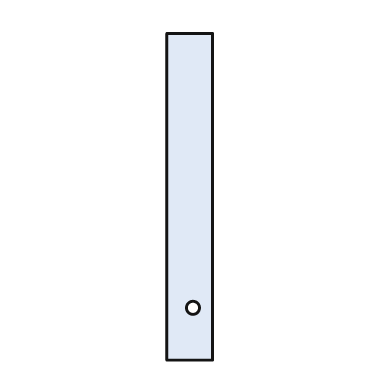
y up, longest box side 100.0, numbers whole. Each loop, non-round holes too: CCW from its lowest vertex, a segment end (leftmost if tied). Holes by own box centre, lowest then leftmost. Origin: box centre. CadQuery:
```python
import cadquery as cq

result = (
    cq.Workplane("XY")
    .moveTo(-7.0, -50.0)
    .lineTo(7.0, -50.0)
    .lineTo(7.0, 50.0)
    .lineTo(-7.0, 50.0)
    .close()
    .moveTo(1.0, -34.0)
    .circle(2.0)
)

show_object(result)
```